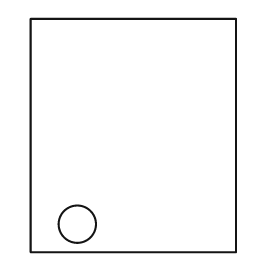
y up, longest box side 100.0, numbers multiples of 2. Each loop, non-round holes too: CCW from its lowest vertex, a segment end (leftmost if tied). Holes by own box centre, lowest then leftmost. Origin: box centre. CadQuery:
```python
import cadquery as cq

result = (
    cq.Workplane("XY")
    .moveTo(-44.0, -50.0)
    .lineTo(44.0, -50.0)
    .lineTo(44.0, 50.0)
    .lineTo(-44.0, 50.0)
    .close()
    .moveTo(-24.0, -38.0)
    .circle(8.0)
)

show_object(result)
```